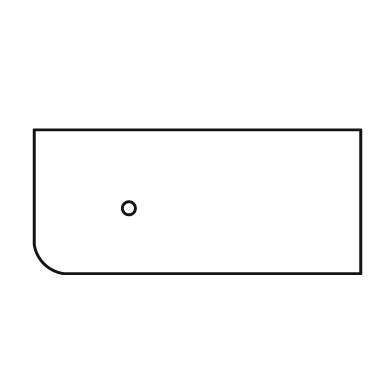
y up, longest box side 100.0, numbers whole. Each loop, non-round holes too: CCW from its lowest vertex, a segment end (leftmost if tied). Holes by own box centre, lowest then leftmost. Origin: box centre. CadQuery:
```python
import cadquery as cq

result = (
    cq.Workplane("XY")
    .moveTo(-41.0, -22.0)
    .lineTo(50.0, -22.0)
    .lineTo(50.0, 22.0)
    .lineTo(-50.0, 22.0)
    .lineTo(-50.0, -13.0)
    .threePointArc((-47.0, -19.0), (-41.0, -22.0))
    .close()
    .moveTo(-21.0, -2.0)
    .circle(2.0)
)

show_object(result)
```